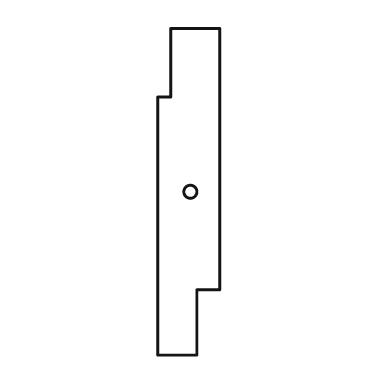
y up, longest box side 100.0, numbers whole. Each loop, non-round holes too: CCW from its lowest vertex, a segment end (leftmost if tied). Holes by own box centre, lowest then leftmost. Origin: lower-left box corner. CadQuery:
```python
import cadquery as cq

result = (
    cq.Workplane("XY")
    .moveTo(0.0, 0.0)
    .lineTo(12.0, 0.0)
    .lineTo(12.0, 20.0)
    .lineTo(19.0, 20.0)
    .lineTo(19.0, 100.0)
    .lineTo(4.0, 100.0)
    .lineTo(4.0, 79.0)
    .lineTo(0.0, 79.0)
    .close()
    .moveTo(10.0, 50.0)
    .circle(2.0)
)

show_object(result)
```